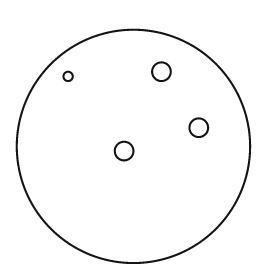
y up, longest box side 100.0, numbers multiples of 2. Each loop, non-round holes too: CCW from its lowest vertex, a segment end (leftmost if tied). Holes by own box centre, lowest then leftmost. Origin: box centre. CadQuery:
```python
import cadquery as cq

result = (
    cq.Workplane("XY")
    .moveTo(0.0, 0.0)
    .circle(50.0)
    .moveTo(-4.0, -2.0)
    .circle(4.0)
    .moveTo(28.0, 8.0)
    .circle(4.0)
    .moveTo(-28.0, 30.0)
    .circle(2.0)
    .moveTo(12.0, 32.0)
    .circle(4.0)
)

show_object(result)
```